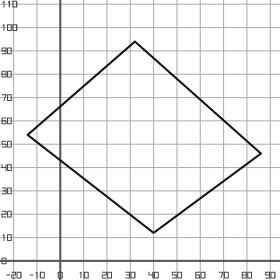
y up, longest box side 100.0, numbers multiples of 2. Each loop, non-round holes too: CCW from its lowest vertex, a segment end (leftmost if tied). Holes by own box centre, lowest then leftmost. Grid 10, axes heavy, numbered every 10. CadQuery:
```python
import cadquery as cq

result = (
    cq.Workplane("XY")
    .moveTo(40.0, 12.0)
    .lineTo(86.0, 46.0)
    .lineTo(32.0, 94.0)
    .lineTo(-14.0, 54.0)
    .close()
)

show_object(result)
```